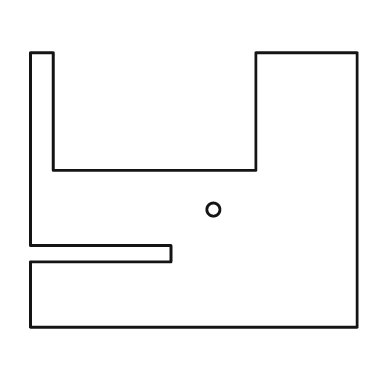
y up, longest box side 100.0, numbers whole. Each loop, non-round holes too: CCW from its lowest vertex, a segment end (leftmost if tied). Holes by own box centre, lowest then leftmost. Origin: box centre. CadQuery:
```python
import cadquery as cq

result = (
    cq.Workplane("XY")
    .moveTo(-50.0, -42.0)
    .lineTo(50.0, -42.0)
    .lineTo(50.0, 42.0)
    .lineTo(19.0, 42.0)
    .lineTo(19.0, 6.0)
    .lineTo(-43.0, 6.0)
    .lineTo(-43.0, 42.0)
    .lineTo(-50.0, 42.0)
    .lineTo(-50.0, -17.0)
    .lineTo(-7.0, -17.0)
    .lineTo(-7.0, -22.0)
    .lineTo(-50.0, -22.0)
    .close()
    .moveTo(6.0, -6.0)
    .circle(2.0)
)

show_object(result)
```